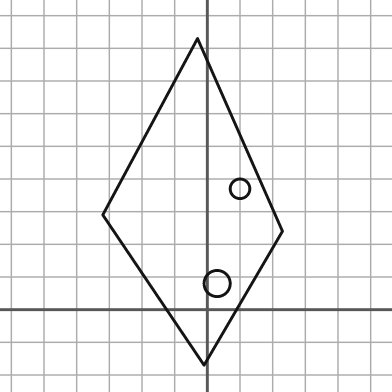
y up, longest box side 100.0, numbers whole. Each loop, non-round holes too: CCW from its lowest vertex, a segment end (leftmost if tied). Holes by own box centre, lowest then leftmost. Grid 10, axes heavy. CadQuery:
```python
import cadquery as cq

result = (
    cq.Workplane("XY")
    .moveTo(-1.0, -17.0)
    .lineTo(23.0, 24.0)
    .lineTo(-3.0, 83.0)
    .lineTo(-32.0, 29.0)
    .close()
    .moveTo(3.0, 8.0)
    .circle(4.0)
    .moveTo(10.0, 37.0)
    .circle(3.0)
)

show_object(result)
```